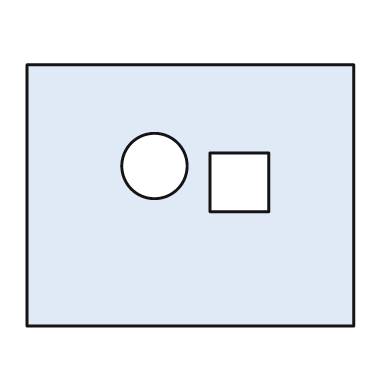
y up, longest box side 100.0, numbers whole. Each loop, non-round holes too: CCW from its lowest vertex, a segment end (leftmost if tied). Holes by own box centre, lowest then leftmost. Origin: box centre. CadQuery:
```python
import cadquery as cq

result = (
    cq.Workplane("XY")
    .moveTo(-50.0, -40.0)
    .lineTo(50.0, -40.0)
    .lineTo(50.0, 40.0)
    .lineTo(-50.0, 40.0)
    .close()
    .moveTo(6.0, -5.0)
    .lineTo(24.0, -5.0)
    .lineTo(24.0, 13.0)
    .lineTo(6.0, 13.0)
    .close()
    .moveTo(-11.0, 9.0)
    .circle(10.0)
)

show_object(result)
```